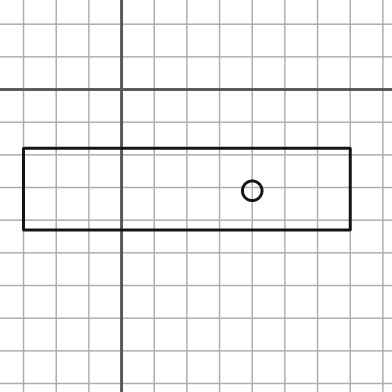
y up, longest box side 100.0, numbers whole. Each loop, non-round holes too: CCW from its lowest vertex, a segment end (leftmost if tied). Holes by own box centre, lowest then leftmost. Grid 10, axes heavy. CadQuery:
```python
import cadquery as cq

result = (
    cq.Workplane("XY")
    .moveTo(-30.0, -43.0)
    .lineTo(70.0, -43.0)
    .lineTo(70.0, -18.0)
    .lineTo(-30.0, -18.0)
    .close()
    .moveTo(40.0, -31.0)
    .circle(3.0)
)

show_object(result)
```